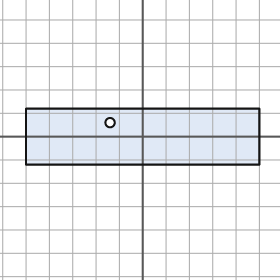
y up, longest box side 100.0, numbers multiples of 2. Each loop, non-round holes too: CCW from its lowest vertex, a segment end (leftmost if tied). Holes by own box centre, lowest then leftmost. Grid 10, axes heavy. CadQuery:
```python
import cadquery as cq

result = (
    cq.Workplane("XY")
    .moveTo(-50.0, -12.0)
    .lineTo(50.0, -12.0)
    .lineTo(50.0, 12.0)
    .lineTo(-50.0, 12.0)
    .close()
    .moveTo(-14.0, 6.0)
    .circle(2.0)
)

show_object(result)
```